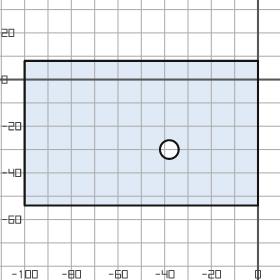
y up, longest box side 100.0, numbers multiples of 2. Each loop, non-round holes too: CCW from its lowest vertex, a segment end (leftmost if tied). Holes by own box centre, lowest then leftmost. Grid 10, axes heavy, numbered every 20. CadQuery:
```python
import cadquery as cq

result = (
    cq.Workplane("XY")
    .moveTo(-100.0, -54.0)
    .lineTo(0.0, -54.0)
    .lineTo(0.0, 8.0)
    .lineTo(-100.0, 8.0)
    .close()
    .moveTo(-38.0, -30.0)
    .circle(4.0)
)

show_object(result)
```